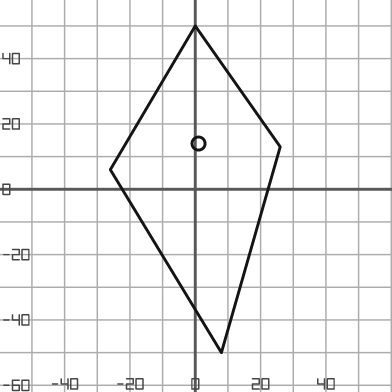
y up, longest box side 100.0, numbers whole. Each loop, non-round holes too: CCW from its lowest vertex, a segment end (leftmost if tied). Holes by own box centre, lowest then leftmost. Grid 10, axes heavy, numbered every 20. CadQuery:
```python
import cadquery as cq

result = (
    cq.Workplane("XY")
    .moveTo(8.0, -50.0)
    .lineTo(26.0, 13.0)
    .lineTo(0.0, 50.0)
    .lineTo(-26.0, 6.0)
    .close()
    .moveTo(1.0, 14.0)
    .circle(2.0)
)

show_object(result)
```